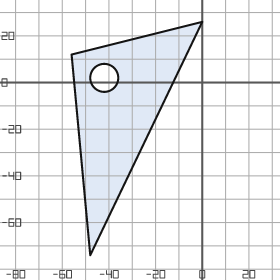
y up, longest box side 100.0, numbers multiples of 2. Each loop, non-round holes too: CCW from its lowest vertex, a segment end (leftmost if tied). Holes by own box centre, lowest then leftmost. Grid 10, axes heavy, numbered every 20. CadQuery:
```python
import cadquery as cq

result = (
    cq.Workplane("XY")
    .moveTo(-48.0, -74.0)
    .lineTo(0.0, 26.0)
    .lineTo(-56.0, 12.0)
    .close()
    .moveTo(-42.0, 2.0)
    .circle(6.0)
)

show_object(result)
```